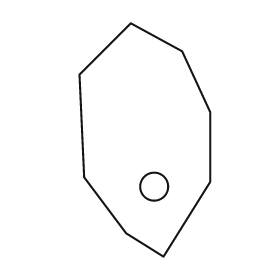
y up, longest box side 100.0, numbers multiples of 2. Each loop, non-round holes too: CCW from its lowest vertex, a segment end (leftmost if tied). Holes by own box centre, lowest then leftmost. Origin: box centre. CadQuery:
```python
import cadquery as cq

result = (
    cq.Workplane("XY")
    .moveTo(8.0, -50.0)
    .lineTo(28.0, -18.0)
    .lineTo(28.0, 12.0)
    .lineTo(16.0, 38.0)
    .lineTo(-6.0, 50.0)
    .lineTo(-28.0, 28.0)
    .lineTo(-26.0, -16.0)
    .lineTo(-8.0, -40.0)
    .close()
    .moveTo(4.0, -20.0)
    .circle(6.0)
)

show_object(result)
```